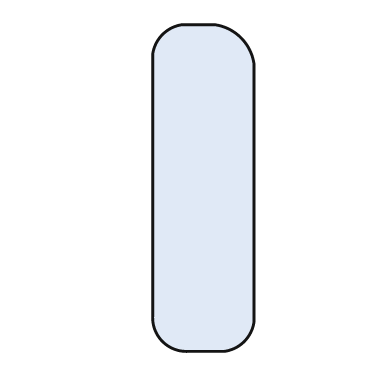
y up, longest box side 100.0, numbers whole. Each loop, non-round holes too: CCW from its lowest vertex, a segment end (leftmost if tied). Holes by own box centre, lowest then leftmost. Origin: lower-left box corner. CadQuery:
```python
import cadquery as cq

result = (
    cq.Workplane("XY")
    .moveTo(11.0, 0.0)
    .lineTo(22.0, 0.0)
    .threePointArc((28.0, 3.0), (31.0, 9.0))
    .lineTo(31.0, 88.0)
    .threePointArc((27.0, 96.0), (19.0, 100.0))
    .lineTo(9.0, 100.0)
    .threePointArc((3.0, 97.0), (0.0, 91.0))
    .lineTo(0.0, 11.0)
    .threePointArc((3.0, 3.0), (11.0, 0.0))
    .close()
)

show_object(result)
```